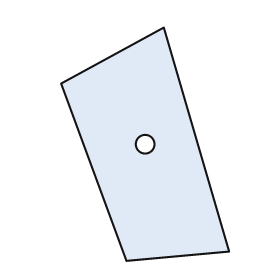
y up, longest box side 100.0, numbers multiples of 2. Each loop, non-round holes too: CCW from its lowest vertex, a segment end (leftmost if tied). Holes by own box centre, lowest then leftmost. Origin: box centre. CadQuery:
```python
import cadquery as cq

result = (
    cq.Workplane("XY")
    .moveTo(-8.0, -50.0)
    .lineTo(36.0, -46.0)
    .lineTo(8.0, 50.0)
    .lineTo(-36.0, 26.0)
    .close()
    .moveTo(0.0, 0.0)
    .circle(4.0)
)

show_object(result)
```